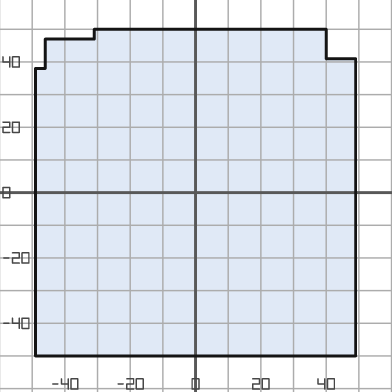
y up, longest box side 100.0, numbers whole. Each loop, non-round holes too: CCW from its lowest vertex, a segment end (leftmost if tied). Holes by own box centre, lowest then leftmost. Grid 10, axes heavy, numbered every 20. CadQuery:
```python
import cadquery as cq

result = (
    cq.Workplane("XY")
    .moveTo(-49.0, -50.0)
    .lineTo(49.0, -50.0)
    .lineTo(49.0, 41.0)
    .lineTo(40.0, 41.0)
    .lineTo(40.0, 50.0)
    .lineTo(-31.0, 50.0)
    .lineTo(-31.0, 47.0)
    .lineTo(-46.0, 47.0)
    .lineTo(-46.0, 38.0)
    .lineTo(-49.0, 38.0)
    .close()
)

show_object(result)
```